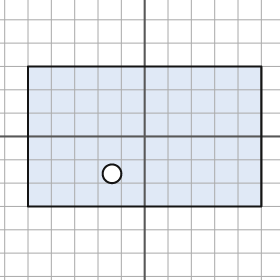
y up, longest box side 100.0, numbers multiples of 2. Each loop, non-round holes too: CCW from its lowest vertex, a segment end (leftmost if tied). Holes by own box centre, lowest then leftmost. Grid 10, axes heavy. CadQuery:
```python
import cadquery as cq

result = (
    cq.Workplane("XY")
    .moveTo(-50.0, -30.0)
    .lineTo(50.0, -30.0)
    .lineTo(50.0, 30.0)
    .lineTo(-50.0, 30.0)
    .close()
    .moveTo(-14.0, -16.0)
    .circle(4.0)
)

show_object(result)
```